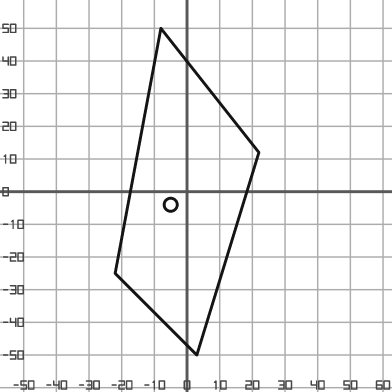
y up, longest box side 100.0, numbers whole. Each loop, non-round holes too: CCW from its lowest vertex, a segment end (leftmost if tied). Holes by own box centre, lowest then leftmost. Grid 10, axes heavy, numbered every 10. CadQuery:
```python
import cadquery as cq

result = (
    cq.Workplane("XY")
    .moveTo(3.0, -50.0)
    .lineTo(22.0, 12.0)
    .lineTo(-8.0, 50.0)
    .lineTo(-22.0, -25.0)
    .close()
    .moveTo(-5.0, -4.0)
    .circle(2.0)
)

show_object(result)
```